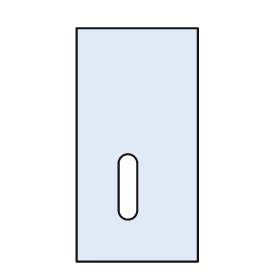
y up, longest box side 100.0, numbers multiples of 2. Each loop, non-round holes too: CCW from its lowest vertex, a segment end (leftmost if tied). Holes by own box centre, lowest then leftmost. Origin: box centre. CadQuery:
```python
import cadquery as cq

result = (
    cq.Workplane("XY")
    .moveTo(-26.0, -50.0)
    .lineTo(26.0, -50.0)
    .lineTo(26.0, 50.0)
    .lineTo(-26.0, 50.0)
    .close()
    .moveTo(-8.0, -28.0)
    .threePointArc((-4.0, -32.0), (0.0, -28.0))
    .lineTo(0.0, -8.0)
    .threePointArc((-4.0, -4.0), (-8.0, -8.0))
    .close()
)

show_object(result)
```